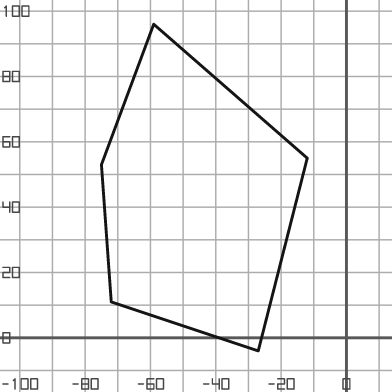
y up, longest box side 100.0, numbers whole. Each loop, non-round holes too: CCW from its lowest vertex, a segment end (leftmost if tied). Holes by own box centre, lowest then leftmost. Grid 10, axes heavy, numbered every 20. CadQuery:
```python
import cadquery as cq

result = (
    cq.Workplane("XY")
    .moveTo(-27.0, -4.0)
    .lineTo(-12.0, 55.0)
    .lineTo(-59.0, 96.0)
    .lineTo(-75.0, 53.0)
    .lineTo(-72.0, 11.0)
    .close()
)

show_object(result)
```